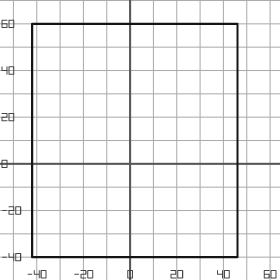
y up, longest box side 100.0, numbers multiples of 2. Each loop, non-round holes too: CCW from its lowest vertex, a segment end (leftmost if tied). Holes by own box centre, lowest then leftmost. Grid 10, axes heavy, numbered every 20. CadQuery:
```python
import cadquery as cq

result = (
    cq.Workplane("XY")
    .moveTo(-42.0, -40.0)
    .lineTo(46.0, -40.0)
    .lineTo(46.0, 60.0)
    .lineTo(-42.0, 60.0)
    .close()
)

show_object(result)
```